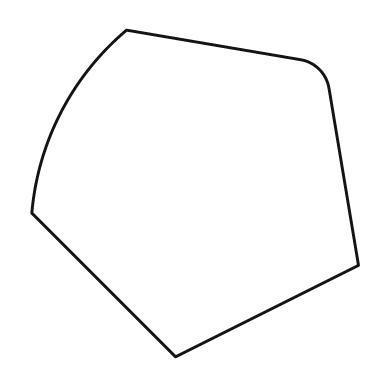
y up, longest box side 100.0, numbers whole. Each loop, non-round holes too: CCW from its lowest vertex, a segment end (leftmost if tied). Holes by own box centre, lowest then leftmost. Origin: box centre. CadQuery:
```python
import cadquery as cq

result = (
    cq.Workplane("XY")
    .moveTo(-6.0, -50.0)
    .lineTo(50.0, -22.0)
    .lineTo(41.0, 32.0)
    .threePointArc((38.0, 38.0), (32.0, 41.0))
    .lineTo(-21.0, 50.0)
    .threePointArc((-41.0, 25.0), (-50.0, -6.0))
    .close()
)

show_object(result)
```